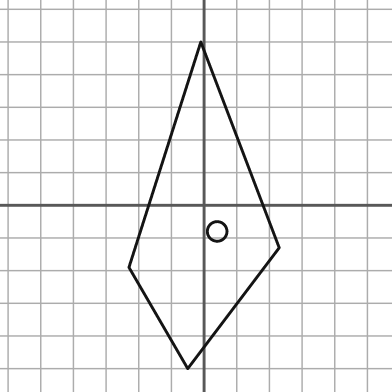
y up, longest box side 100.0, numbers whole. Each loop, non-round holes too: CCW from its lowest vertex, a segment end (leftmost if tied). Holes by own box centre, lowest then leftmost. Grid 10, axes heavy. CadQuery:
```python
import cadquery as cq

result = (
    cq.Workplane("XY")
    .moveTo(-5.0, -50.0)
    .lineTo(23.0, -13.0)
    .lineTo(-1.0, 50.0)
    .lineTo(-23.0, -19.0)
    .close()
    .moveTo(4.0, -8.0)
    .circle(3.0)
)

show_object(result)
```